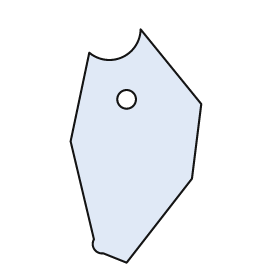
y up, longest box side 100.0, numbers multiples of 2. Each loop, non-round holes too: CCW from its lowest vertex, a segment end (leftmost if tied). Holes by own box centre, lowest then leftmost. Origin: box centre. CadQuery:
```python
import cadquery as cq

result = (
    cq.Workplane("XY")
    .moveTo(-4.0, -50.0)
    .lineTo(24.0, -14.0)
    .lineTo(28.0, 18.0)
    .lineTo(2.0, 50.0)
    .threePointArc((-6.0, 38.0), (-20.0, 40.0))
    .lineTo(-28.0, 2.0)
    .lineTo(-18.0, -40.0)
    .threePointArc((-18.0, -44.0), (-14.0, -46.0))
    .close()
    .moveTo(-4.0, 20.0)
    .circle(4.0)
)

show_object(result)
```